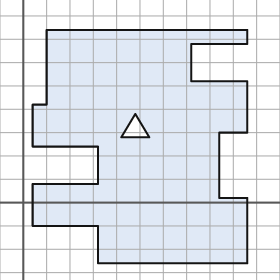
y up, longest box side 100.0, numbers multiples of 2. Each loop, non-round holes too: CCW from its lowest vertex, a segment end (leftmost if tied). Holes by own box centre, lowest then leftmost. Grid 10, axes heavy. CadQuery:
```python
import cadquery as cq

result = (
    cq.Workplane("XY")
    .moveTo(32.0, -26.0)
    .lineTo(96.0, -26.0)
    .lineTo(96.0, 2.0)
    .lineTo(84.0, 2.0)
    .lineTo(84.0, 30.0)
    .lineTo(96.0, 30.0)
    .lineTo(96.0, 52.0)
    .lineTo(72.0, 52.0)
    .lineTo(72.0, 68.0)
    .lineTo(96.0, 68.0)
    .lineTo(96.0, 74.0)
    .lineTo(10.0, 74.0)
    .lineTo(10.0, 42.0)
    .lineTo(4.0, 42.0)
    .lineTo(4.0, 24.0)
    .lineTo(32.0, 24.0)
    .lineTo(32.0, 8.0)
    .lineTo(4.0, 8.0)
    .lineTo(4.0, -10.0)
    .lineTo(32.0, -10.0)
    .close()
    .moveTo(42.0, 28.0)
    .lineTo(54.0, 28.0)
    .lineTo(48.0, 38.0)
    .close()
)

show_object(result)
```